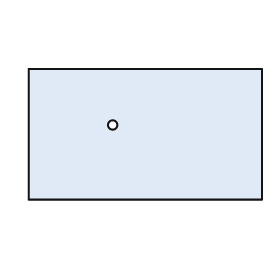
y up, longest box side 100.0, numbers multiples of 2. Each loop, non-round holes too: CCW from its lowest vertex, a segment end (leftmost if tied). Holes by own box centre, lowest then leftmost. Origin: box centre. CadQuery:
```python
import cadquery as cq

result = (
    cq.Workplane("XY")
    .moveTo(-50.0, -28.0)
    .lineTo(50.0, -28.0)
    .lineTo(50.0, 28.0)
    .lineTo(-50.0, 28.0)
    .close()
    .moveTo(-14.0, 4.0)
    .circle(2.0)
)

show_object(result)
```